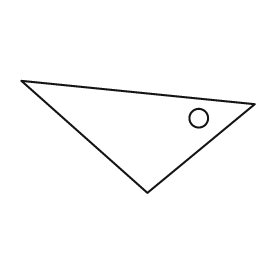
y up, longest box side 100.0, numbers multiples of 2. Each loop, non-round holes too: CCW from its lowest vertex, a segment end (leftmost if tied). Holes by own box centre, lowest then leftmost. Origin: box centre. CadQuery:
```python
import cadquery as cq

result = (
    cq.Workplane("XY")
    .moveTo(4.0, -24.0)
    .lineTo(50.0, 14.0)
    .lineTo(-50.0, 24.0)
    .close()
    .moveTo(26.0, 8.0)
    .circle(4.0)
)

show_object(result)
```